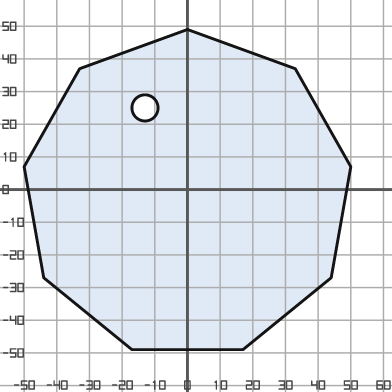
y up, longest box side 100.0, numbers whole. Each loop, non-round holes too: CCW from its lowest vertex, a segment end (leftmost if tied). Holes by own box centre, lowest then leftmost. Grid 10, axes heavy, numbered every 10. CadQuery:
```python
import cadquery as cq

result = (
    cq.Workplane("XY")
    .moveTo(-17.0, -49.0)
    .lineTo(17.0, -49.0)
    .lineTo(44.0, -27.0)
    .lineTo(50.0, 7.0)
    .lineTo(33.0, 37.0)
    .lineTo(0.0, 49.0)
    .lineTo(-33.0, 37.0)
    .lineTo(-50.0, 7.0)
    .lineTo(-44.0, -27.0)
    .close()
    .moveTo(-13.0, 25.0)
    .circle(4.0)
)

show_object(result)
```